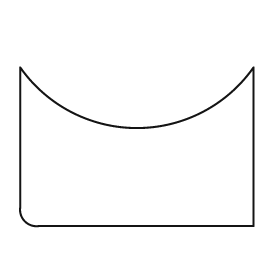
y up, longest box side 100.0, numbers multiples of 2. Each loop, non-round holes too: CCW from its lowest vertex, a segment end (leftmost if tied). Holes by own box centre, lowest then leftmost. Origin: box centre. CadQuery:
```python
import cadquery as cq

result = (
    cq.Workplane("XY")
    .moveTo(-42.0, -34.0)
    .lineTo(50.0, -34.0)
    .lineTo(50.0, 34.0)
    .threePointArc((0.0, 8.0), (-50.0, 34.0))
    .lineTo(-50.0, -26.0)
    .threePointArc((-48.0, -32.0), (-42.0, -34.0))
    .close()
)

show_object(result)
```